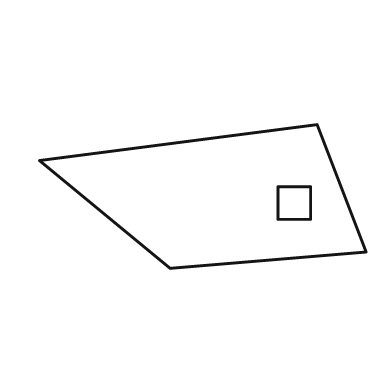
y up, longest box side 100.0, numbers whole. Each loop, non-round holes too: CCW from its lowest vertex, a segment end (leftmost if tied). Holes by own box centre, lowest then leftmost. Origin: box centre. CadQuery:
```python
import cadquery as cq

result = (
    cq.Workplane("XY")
    .moveTo(-10.0, -22.0)
    .lineTo(50.0, -17.0)
    .lineTo(35.0, 22.0)
    .lineTo(-50.0, 11.0)
    .close()
    .moveTo(23.0, -7.0)
    .lineTo(33.0, -7.0)
    .lineTo(33.0, 3.0)
    .lineTo(23.0, 3.0)
    .close()
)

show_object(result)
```